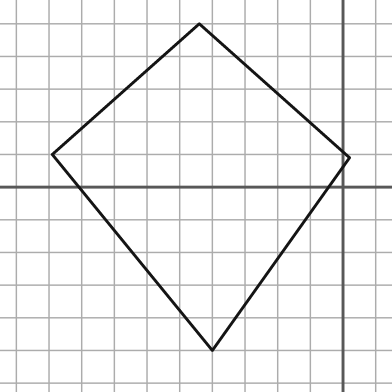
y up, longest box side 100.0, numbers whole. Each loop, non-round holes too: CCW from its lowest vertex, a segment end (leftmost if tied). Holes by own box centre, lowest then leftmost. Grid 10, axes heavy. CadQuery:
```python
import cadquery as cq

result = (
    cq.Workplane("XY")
    .moveTo(-40.0, -50.0)
    .lineTo(2.0, 9.0)
    .lineTo(-44.0, 50.0)
    .lineTo(-89.0, 10.0)
    .close()
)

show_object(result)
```